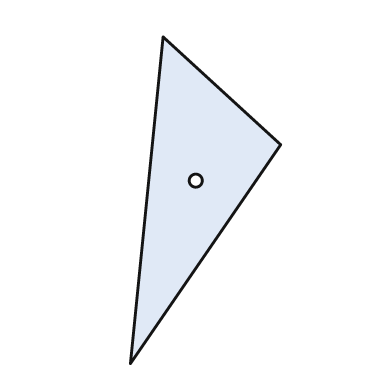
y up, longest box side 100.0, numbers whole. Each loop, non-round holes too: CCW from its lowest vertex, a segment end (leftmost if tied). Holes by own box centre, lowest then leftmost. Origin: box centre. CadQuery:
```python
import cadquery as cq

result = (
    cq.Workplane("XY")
    .moveTo(-23.0, -50.0)
    .lineTo(23.0, 17.0)
    .lineTo(-13.0, 50.0)
    .close()
    .moveTo(-3.0, 6.0)
    .circle(2.0)
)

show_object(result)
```